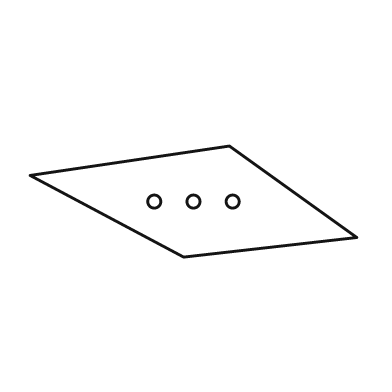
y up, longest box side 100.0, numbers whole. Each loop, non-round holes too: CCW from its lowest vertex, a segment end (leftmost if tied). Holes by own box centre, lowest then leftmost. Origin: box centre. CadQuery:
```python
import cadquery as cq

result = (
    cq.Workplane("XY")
    .moveTo(-3.0, -17.0)
    .lineTo(50.0, -11.0)
    .lineTo(11.0, 17.0)
    .lineTo(-50.0, 8.0)
    .close()
    .moveTo(-12.0, 0.0)
    .circle(2.0)
    .moveTo(0.0, 0.0)
    .circle(2.0)
    .moveTo(12.0, 0.0)
    .circle(2.0)
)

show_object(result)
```